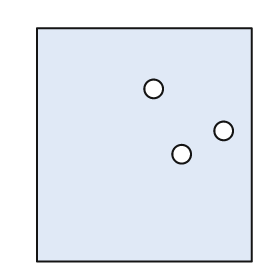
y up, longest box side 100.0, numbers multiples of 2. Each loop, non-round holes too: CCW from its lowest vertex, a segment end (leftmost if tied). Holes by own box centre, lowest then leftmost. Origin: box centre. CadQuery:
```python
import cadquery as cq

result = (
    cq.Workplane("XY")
    .moveTo(-46.0, -50.0)
    .lineTo(46.0, -50.0)
    .lineTo(46.0, 50.0)
    .lineTo(-46.0, 50.0)
    .close()
    .moveTo(16.0, -4.0)
    .circle(4.0)
    .moveTo(34.0, 6.0)
    .circle(4.0)
    .moveTo(4.0, 24.0)
    .circle(4.0)
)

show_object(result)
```